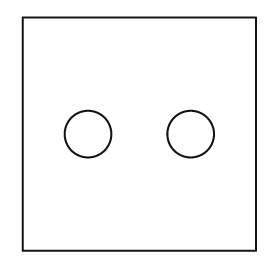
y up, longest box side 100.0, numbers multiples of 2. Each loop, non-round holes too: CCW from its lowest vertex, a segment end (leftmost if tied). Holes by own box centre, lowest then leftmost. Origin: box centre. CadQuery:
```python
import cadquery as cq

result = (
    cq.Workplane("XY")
    .moveTo(-50.0, -50.0)
    .lineTo(50.0, -50.0)
    .lineTo(50.0, 50.0)
    .lineTo(-50.0, 50.0)
    .close()
    .moveTo(-22.0, 0.0)
    .circle(10.0)
    .moveTo(22.0, 0.0)
    .circle(10.0)
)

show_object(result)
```